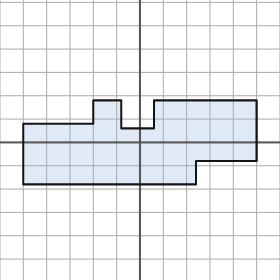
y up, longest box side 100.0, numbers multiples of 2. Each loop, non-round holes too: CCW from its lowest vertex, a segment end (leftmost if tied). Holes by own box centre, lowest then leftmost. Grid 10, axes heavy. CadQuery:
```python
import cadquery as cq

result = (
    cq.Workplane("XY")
    .moveTo(-50.0, -18.0)
    .lineTo(24.0, -18.0)
    .lineTo(24.0, -8.0)
    .lineTo(50.0, -8.0)
    .lineTo(50.0, 18.0)
    .lineTo(6.0, 18.0)
    .lineTo(6.0, 6.0)
    .lineTo(-8.0, 6.0)
    .lineTo(-8.0, 18.0)
    .lineTo(-20.0, 18.0)
    .lineTo(-20.0, 8.0)
    .lineTo(-50.0, 8.0)
    .close()
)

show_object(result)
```